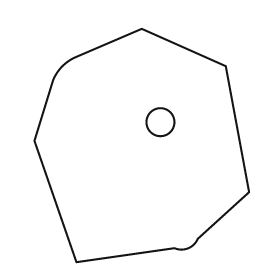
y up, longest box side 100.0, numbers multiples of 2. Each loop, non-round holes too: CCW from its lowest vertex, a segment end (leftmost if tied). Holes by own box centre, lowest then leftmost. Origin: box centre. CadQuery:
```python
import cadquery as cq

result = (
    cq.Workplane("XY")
    .moveTo(-28.0, -50.0)
    .lineTo(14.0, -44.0)
    .threePointArc((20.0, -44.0), (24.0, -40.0))
    .lineTo(46.0, -20.0)
    .lineTo(36.0, 34.0)
    .lineTo(0.0, 50.0)
    .lineTo(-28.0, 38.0)
    .threePointArc((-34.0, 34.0), (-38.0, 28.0))
    .lineTo(-46.0, 2.0)
    .close()
    .moveTo(8.0, 10.0)
    .circle(6.0)
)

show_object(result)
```